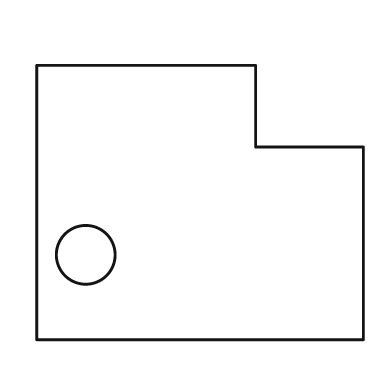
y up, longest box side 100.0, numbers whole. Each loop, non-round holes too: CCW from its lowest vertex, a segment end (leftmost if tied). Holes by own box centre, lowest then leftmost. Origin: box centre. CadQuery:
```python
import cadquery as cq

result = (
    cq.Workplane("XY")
    .moveTo(-50.0, -42.0)
    .lineTo(50.0, -42.0)
    .lineTo(50.0, 17.0)
    .lineTo(17.0, 17.0)
    .lineTo(17.0, 42.0)
    .lineTo(-50.0, 42.0)
    .close()
    .moveTo(-35.0, -16.0)
    .circle(9.0)
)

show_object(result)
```